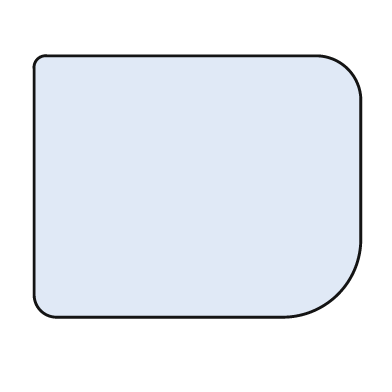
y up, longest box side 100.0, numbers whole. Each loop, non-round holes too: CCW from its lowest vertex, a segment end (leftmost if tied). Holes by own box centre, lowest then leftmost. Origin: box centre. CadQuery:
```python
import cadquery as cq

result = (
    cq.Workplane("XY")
    .moveTo(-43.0, -40.0)
    .lineTo(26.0, -40.0)
    .threePointArc((43.0, -33.0), (50.0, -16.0))
    .lineTo(50.0, 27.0)
    .threePointArc((46.0, 36.0), (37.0, 40.0))
    .lineTo(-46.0, 40.0)
    .threePointArc((-49.0, 39.0), (-50.0, 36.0))
    .lineTo(-50.0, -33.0)
    .threePointArc((-48.0, -38.0), (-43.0, -40.0))
    .close()
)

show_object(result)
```